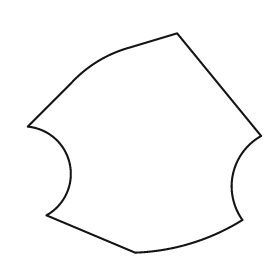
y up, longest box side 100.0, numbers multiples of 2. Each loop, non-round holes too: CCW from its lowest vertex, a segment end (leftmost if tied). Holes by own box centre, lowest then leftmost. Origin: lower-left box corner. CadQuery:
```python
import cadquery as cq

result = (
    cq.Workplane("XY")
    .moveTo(46.0, 0.0)
    .threePointArc((70.0, 4.0), (92.0, 14.0))
    .threePointArc((88.0, 34.0), (100.0, 50.0))
    .lineTo(64.0, 94.0)
    .lineTo(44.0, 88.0)
    .threePointArc((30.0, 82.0), (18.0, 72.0))
    .lineTo(0.0, 54.0)
    .threePointArc((18.0, 38.0), (8.0, 16.0))
    .close()
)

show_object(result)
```